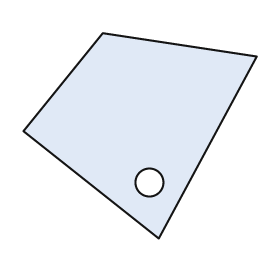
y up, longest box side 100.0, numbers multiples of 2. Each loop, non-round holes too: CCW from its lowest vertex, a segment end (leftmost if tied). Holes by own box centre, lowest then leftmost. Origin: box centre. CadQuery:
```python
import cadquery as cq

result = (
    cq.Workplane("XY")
    .moveTo(8.0, -44.0)
    .lineTo(50.0, 34.0)
    .lineTo(-16.0, 44.0)
    .lineTo(-50.0, 2.0)
    .close()
    .moveTo(4.0, -20.0)
    .circle(6.0)
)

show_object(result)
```